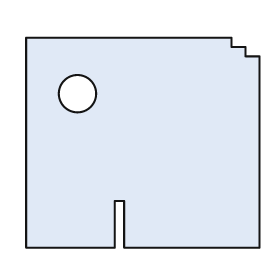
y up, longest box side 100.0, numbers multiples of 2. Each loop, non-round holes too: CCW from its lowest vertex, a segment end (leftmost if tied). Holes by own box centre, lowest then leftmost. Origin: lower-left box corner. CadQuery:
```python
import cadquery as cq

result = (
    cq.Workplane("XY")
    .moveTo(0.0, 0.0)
    .lineTo(38.0, 0.0)
    .lineTo(38.0, 20.0)
    .lineTo(42.0, 20.0)
    .lineTo(42.0, 0.0)
    .lineTo(100.0, 0.0)
    .lineTo(100.0, 82.0)
    .lineTo(94.0, 82.0)
    .lineTo(94.0, 86.0)
    .lineTo(88.0, 86.0)
    .lineTo(88.0, 90.0)
    .lineTo(0.0, 90.0)
    .close()
    .moveTo(22.0, 66.0)
    .circle(8.0)
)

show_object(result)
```